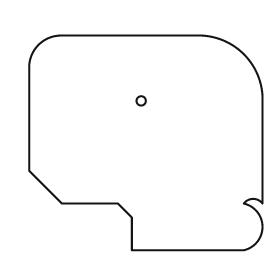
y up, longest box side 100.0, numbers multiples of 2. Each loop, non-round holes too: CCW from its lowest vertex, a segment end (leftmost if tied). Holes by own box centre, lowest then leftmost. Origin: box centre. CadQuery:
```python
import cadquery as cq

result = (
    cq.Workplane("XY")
    .moveTo(-6.0, -46.0)
    .lineTo(42.0, -46.0)
    .threePointArc((50.0, -36.0), (42.0, -26.0))
    .threePointArc((46.0, -24.0), (50.0, -26.0))
    .lineTo(50.0, 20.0)
    .threePointArc((42.0, 38.0), (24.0, 46.0))
    .lineTo(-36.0, 46.0)
    .threePointArc((-46.0, 42.0), (-50.0, 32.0))
    .lineTo(-50.0, -12.0)
    .lineTo(-36.0, -26.0)
    .lineTo(-12.0, -26.0)
    .lineTo(-6.0, -32.0)
    .close()
    .moveTo(-2.0, 18.0)
    .circle(2.0)
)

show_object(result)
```